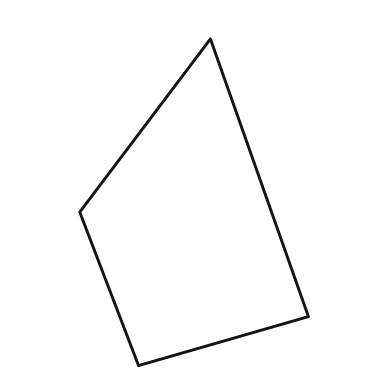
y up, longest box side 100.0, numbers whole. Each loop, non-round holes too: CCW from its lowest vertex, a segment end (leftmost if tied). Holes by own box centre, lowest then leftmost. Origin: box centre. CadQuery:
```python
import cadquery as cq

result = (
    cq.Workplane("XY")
    .moveTo(-17.0, -50.0)
    .lineTo(35.0, -35.0)
    .lineTo(5.0, 50.0)
    .lineTo(-35.0, -3.0)
    .close()
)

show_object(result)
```